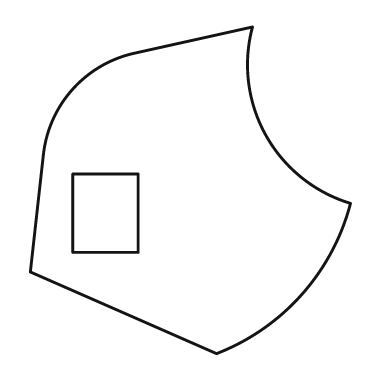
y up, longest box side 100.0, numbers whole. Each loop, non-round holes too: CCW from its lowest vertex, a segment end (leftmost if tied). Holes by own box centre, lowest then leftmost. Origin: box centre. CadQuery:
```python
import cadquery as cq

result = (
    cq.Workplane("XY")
    .moveTo(8.0, -50.0)
    .threePointArc((34.0, -32.0), (49.0, -4.0))
    .threePointArc((23.0, 17.0), (19.0, 50.0))
    .lineTo(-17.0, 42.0)
    .threePointArc((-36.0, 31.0), (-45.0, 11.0))
    .lineTo(-49.0, -25.0)
    .close()
    .moveTo(-36.0, -19.0)
    .lineTo(-16.0, -19.0)
    .lineTo(-16.0, 5.0)
    .lineTo(-36.0, 5.0)
    .close()
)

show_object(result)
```